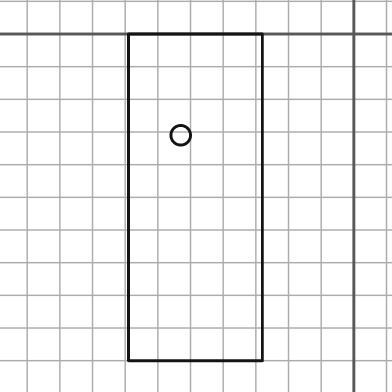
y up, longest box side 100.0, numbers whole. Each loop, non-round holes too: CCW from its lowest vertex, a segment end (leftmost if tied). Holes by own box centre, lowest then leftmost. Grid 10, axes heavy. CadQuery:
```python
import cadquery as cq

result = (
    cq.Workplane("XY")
    .moveTo(-69.0, -100.0)
    .lineTo(-28.0, -100.0)
    .lineTo(-28.0, 0.0)
    .lineTo(-69.0, 0.0)
    .close()
    .moveTo(-53.0, -31.0)
    .circle(3.0)
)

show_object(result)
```